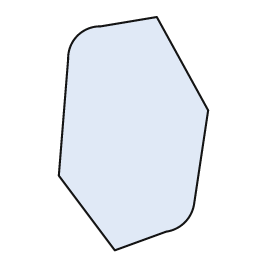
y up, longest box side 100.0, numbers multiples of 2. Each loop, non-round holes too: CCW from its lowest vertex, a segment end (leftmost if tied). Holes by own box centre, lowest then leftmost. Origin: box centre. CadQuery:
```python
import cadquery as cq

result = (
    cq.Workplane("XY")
    .moveTo(-8.0, -50.0)
    .lineTo(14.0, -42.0)
    .threePointArc((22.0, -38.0), (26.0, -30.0))
    .lineTo(32.0, 10.0)
    .lineTo(10.0, 50.0)
    .lineTo(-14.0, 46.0)
    .threePointArc((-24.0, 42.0), (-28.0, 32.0))
    .lineTo(-32.0, -18.0)
    .close()
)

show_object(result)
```